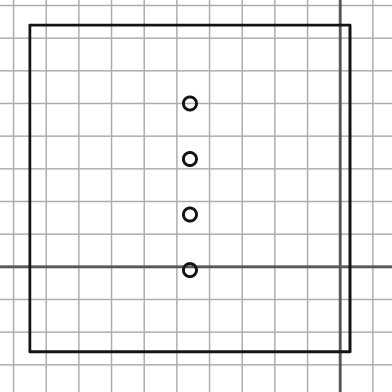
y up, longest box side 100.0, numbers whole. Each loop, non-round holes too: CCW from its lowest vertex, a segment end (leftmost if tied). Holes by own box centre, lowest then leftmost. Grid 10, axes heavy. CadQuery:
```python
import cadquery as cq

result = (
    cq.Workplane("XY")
    .moveTo(-95.0, -26.0)
    .lineTo(3.0, -26.0)
    .lineTo(3.0, 74.0)
    .lineTo(-95.0, 74.0)
    .close()
    .moveTo(-46.0, -1.0)
    .circle(2.0)
    .moveTo(-46.0, 16.0)
    .circle(2.0)
    .moveTo(-46.0, 33.0)
    .circle(2.0)
    .moveTo(-46.0, 50.0)
    .circle(2.0)
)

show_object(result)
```